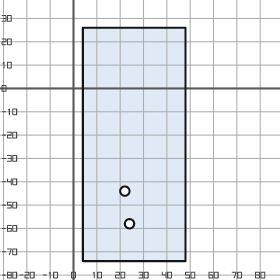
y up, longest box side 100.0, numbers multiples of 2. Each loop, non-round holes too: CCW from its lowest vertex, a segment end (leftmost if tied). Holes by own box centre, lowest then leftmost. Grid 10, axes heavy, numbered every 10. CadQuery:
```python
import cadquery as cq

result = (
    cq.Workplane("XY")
    .moveTo(4.0, -74.0)
    .lineTo(48.0, -74.0)
    .lineTo(48.0, 26.0)
    .lineTo(4.0, 26.0)
    .close()
    .moveTo(24.0, -58.0)
    .circle(2.0)
    .moveTo(22.0, -44.0)
    .circle(2.0)
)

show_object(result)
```